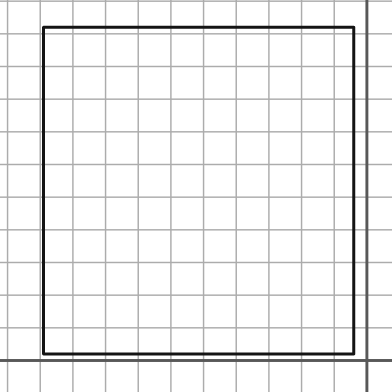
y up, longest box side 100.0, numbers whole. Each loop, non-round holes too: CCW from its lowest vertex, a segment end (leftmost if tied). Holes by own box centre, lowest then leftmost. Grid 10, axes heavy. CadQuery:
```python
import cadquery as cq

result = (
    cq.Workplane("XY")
    .moveTo(-99.0, 2.0)
    .lineTo(-4.0, 2.0)
    .lineTo(-4.0, 102.0)
    .lineTo(-99.0, 102.0)
    .close()
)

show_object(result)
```